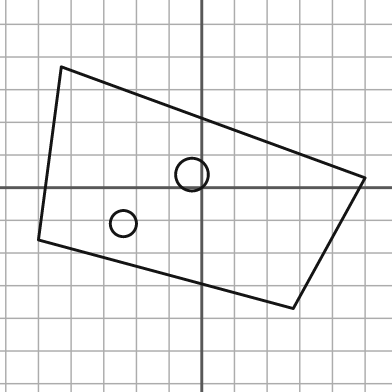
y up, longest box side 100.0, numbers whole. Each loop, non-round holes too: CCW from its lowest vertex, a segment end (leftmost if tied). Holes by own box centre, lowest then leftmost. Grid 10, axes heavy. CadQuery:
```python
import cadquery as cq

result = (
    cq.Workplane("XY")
    .moveTo(28.0, -37.0)
    .lineTo(50.0, 3.0)
    .lineTo(-43.0, 37.0)
    .lineTo(-50.0, -16.0)
    .close()
    .moveTo(-24.0, -11.0)
    .circle(4.0)
    .moveTo(-3.0, 4.0)
    .circle(5.0)
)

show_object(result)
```